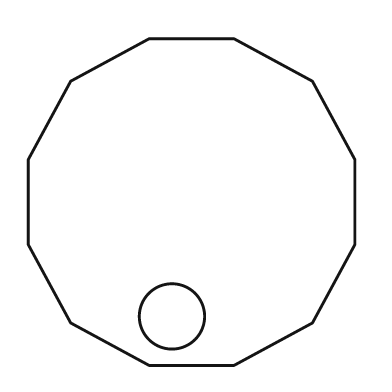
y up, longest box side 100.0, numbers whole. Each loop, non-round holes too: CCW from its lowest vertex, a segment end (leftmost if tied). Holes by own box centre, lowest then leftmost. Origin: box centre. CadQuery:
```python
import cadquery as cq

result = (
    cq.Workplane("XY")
    .moveTo(-13.0, -50.0)
    .lineTo(13.0, -50.0)
    .lineTo(37.0, -37.0)
    .lineTo(50.0, -13.0)
    .lineTo(50.0, 13.0)
    .lineTo(37.0, 37.0)
    .lineTo(13.0, 50.0)
    .lineTo(-13.0, 50.0)
    .lineTo(-37.0, 37.0)
    .lineTo(-50.0, 13.0)
    .lineTo(-50.0, -13.0)
    .lineTo(-37.0, -37.0)
    .close()
    .moveTo(-6.0, -35.0)
    .circle(10.0)
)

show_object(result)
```